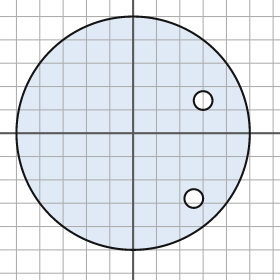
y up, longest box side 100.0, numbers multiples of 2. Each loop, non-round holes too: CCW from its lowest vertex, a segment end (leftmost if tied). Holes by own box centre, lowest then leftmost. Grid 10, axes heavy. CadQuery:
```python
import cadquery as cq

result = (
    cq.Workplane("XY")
    .moveTo(0.0, 0.0)
    .circle(50.0)
    .moveTo(26.0, -28.0)
    .circle(4.0)
    .moveTo(30.0, 14.0)
    .circle(4.0)
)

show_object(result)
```